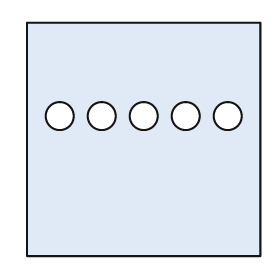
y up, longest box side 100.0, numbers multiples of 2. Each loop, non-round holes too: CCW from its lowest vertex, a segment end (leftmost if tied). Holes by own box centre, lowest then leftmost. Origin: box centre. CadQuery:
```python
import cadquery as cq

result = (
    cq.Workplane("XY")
    .moveTo(-50.0, -50.0)
    .lineTo(50.0, -50.0)
    .lineTo(50.0, 50.0)
    .lineTo(-50.0, 50.0)
    .close()
    .moveTo(-36.0, 10.0)
    .circle(6.0)
    .moveTo(-18.0, 10.0)
    .circle(6.0)
    .moveTo(0.0, 10.0)
    .circle(6.0)
    .moveTo(18.0, 10.0)
    .circle(6.0)
    .moveTo(36.0, 10.0)
    .circle(6.0)
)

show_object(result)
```